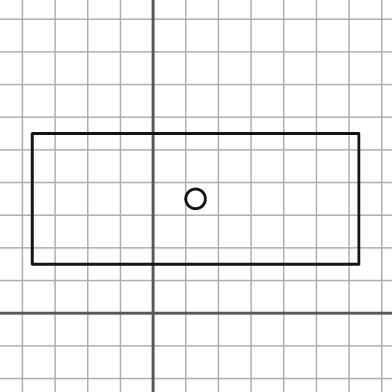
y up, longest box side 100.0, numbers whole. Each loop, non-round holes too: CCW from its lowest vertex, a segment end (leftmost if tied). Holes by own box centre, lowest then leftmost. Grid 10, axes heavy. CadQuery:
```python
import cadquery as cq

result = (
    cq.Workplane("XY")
    .moveTo(-37.0, 15.0)
    .lineTo(63.0, 15.0)
    .lineTo(63.0, 55.0)
    .lineTo(-37.0, 55.0)
    .close()
    .moveTo(13.0, 35.0)
    .circle(3.0)
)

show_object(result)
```